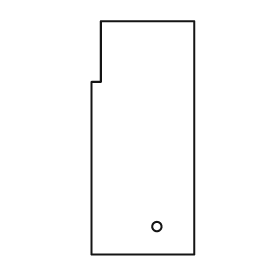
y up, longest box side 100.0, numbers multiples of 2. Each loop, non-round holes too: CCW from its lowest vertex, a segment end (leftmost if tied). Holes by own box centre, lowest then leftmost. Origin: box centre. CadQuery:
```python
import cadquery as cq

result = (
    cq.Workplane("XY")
    .moveTo(-22.0, -50.0)
    .lineTo(22.0, -50.0)
    .lineTo(22.0, 50.0)
    .lineTo(-18.0, 50.0)
    .lineTo(-18.0, 24.0)
    .lineTo(-22.0, 24.0)
    .close()
    .moveTo(6.0, -38.0)
    .circle(2.0)
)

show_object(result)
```